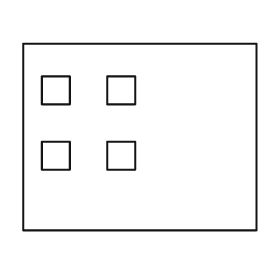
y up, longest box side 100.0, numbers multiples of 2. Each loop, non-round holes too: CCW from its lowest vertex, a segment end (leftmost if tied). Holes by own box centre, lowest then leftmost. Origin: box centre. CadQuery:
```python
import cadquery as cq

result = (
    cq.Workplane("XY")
    .moveTo(-50.0, -40.0)
    .lineTo(50.0, -40.0)
    .lineTo(50.0, 40.0)
    .lineTo(-50.0, 40.0)
    .close()
    .moveTo(-42.0, -14.0)
    .lineTo(-30.0, -14.0)
    .lineTo(-30.0, -2.0)
    .lineTo(-42.0, -2.0)
    .close()
    .moveTo(-14.0, -14.0)
    .lineTo(-2.0, -14.0)
    .lineTo(-2.0, -2.0)
    .lineTo(-14.0, -2.0)
    .close()
    .moveTo(-42.0, 14.0)
    .lineTo(-30.0, 14.0)
    .lineTo(-30.0, 26.0)
    .lineTo(-42.0, 26.0)
    .close()
    .moveTo(-14.0, 14.0)
    .lineTo(-2.0, 14.0)
    .lineTo(-2.0, 26.0)
    .lineTo(-14.0, 26.0)
    .close()
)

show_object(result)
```